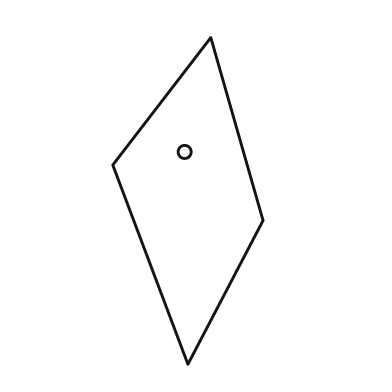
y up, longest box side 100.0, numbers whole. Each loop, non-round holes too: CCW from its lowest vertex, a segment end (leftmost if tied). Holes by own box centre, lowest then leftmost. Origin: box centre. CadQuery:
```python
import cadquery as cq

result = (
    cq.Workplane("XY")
    .moveTo(0.0, -50.0)
    .lineTo(23.0, -6.0)
    .lineTo(7.0, 50.0)
    .lineTo(-23.0, 11.0)
    .close()
    .moveTo(-1.0, 15.0)
    .circle(2.0)
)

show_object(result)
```